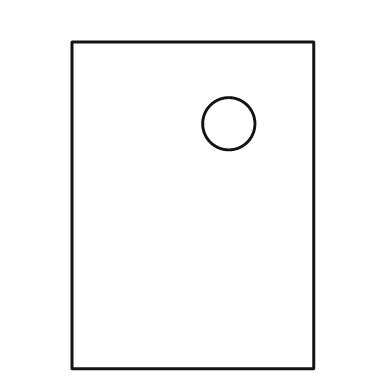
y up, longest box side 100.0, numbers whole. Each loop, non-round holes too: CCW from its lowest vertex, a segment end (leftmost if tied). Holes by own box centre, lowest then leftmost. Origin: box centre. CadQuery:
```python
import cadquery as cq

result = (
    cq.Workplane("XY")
    .moveTo(-37.0, -50.0)
    .lineTo(37.0, -50.0)
    .lineTo(37.0, 50.0)
    .lineTo(-37.0, 50.0)
    .close()
    .moveTo(11.0, 25.0)
    .circle(8.0)
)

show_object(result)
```